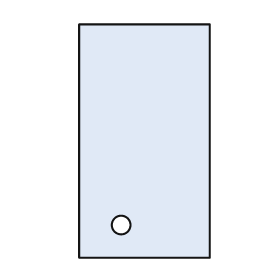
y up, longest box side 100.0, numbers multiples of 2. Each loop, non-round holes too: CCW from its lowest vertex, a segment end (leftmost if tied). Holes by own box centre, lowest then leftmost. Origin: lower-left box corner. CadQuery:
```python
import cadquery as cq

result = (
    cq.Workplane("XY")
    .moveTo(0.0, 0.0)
    .lineTo(56.0, 0.0)
    .lineTo(56.0, 100.0)
    .lineTo(0.0, 100.0)
    .close()
    .moveTo(18.0, 14.0)
    .circle(4.0)
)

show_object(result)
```